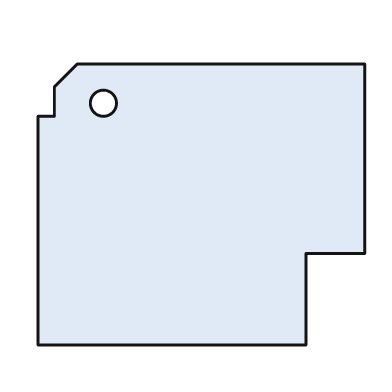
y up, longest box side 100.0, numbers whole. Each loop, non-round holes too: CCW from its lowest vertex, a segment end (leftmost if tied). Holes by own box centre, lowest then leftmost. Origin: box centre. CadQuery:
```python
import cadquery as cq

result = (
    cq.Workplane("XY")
    .moveTo(-50.0, -43.0)
    .lineTo(32.0, -43.0)
    .lineTo(32.0, -15.0)
    .lineTo(50.0, -15.0)
    .lineTo(50.0, 43.0)
    .lineTo(-38.0, 43.0)
    .lineTo(-45.0, 36.0)
    .lineTo(-45.0, 27.0)
    .lineTo(-50.0, 27.0)
    .close()
    .moveTo(-30.0, 31.0)
    .circle(4.0)
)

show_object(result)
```